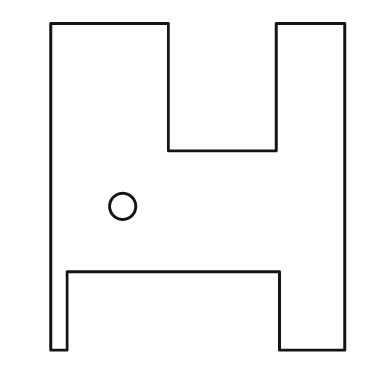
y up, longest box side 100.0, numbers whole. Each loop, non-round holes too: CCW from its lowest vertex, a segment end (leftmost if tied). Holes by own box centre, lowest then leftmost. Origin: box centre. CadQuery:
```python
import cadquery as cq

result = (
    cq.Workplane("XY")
    .moveTo(-45.0, -50.0)
    .lineTo(-40.0, -50.0)
    .lineTo(-40.0, -26.0)
    .lineTo(25.0, -26.0)
    .lineTo(25.0, -50.0)
    .lineTo(45.0, -50.0)
    .lineTo(45.0, 50.0)
    .lineTo(24.0, 50.0)
    .lineTo(24.0, 11.0)
    .lineTo(-9.0, 11.0)
    .lineTo(-9.0, 50.0)
    .lineTo(-45.0, 50.0)
    .close()
    .moveTo(-23.0, -6.0)
    .circle(4.0)
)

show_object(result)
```